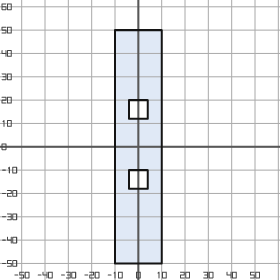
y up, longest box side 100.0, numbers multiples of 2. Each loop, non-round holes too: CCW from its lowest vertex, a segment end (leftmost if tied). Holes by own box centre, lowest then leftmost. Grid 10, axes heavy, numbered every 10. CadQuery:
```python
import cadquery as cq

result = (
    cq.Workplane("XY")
    .moveTo(-10.0, -50.0)
    .lineTo(10.0, -50.0)
    .lineTo(10.0, 50.0)
    .lineTo(-10.0, 50.0)
    .close()
    .moveTo(-4.0, -18.0)
    .lineTo(4.0, -18.0)
    .lineTo(4.0, -10.0)
    .lineTo(-4.0, -10.0)
    .close()
    .moveTo(-4.0, 12.0)
    .lineTo(4.0, 12.0)
    .lineTo(4.0, 20.0)
    .lineTo(-4.0, 20.0)
    .close()
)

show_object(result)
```